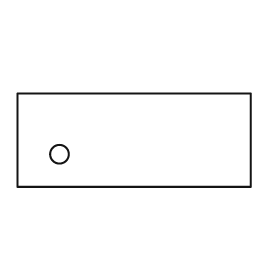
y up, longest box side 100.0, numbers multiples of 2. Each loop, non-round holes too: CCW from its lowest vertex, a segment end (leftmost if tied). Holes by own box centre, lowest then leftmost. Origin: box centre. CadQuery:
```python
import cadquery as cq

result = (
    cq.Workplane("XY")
    .moveTo(-50.0, -20.0)
    .lineTo(50.0, -20.0)
    .lineTo(50.0, 20.0)
    .lineTo(-50.0, 20.0)
    .close()
    .moveTo(-32.0, -6.0)
    .circle(4.0)
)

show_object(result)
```